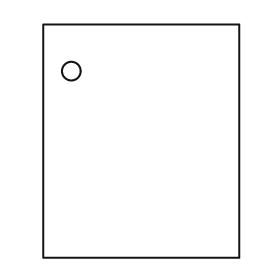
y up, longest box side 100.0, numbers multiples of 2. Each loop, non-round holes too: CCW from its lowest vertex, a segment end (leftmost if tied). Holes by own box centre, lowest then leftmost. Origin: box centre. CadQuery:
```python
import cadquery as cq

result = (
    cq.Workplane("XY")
    .moveTo(-42.0, -50.0)
    .lineTo(42.0, -50.0)
    .lineTo(42.0, 50.0)
    .lineTo(-42.0, 50.0)
    .close()
    .moveTo(-30.0, 30.0)
    .circle(4.0)
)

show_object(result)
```